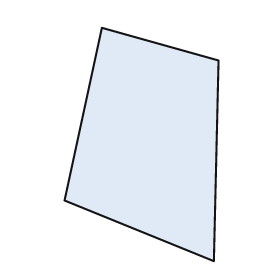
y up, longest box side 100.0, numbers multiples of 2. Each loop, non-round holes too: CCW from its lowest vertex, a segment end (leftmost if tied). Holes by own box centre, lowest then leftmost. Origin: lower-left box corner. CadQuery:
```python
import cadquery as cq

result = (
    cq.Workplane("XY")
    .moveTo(64.0, 0.0)
    .lineTo(66.0, 86.0)
    .lineTo(16.0, 100.0)
    .lineTo(0.0, 26.0)
    .close()
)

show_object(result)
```